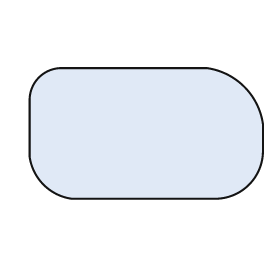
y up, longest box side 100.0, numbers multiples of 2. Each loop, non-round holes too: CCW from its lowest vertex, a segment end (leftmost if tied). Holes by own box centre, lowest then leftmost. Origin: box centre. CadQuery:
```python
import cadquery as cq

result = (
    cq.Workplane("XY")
    .moveTo(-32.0, -28.0)
    .lineTo(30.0, -28.0)
    .threePointArc((44.0, -22.0), (50.0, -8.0))
    .lineTo(50.0, 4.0)
    .threePointArc((42.0, 20.0), (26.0, 28.0))
    .lineTo(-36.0, 28.0)
    .threePointArc((-46.0, 24.0), (-50.0, 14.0))
    .lineTo(-50.0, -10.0)
    .threePointArc((-44.0, -22.0), (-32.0, -28.0))
    .close()
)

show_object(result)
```